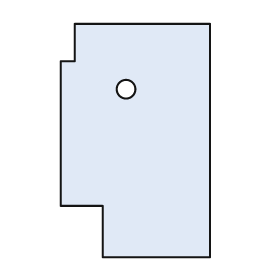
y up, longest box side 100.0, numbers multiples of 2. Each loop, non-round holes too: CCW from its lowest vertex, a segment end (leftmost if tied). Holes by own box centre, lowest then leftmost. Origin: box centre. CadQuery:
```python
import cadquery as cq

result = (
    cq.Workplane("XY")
    .moveTo(-14.0, -50.0)
    .lineTo(32.0, -50.0)
    .lineTo(32.0, 50.0)
    .lineTo(-26.0, 50.0)
    .lineTo(-26.0, 34.0)
    .lineTo(-32.0, 34.0)
    .lineTo(-32.0, -28.0)
    .lineTo(-14.0, -28.0)
    .close()
    .moveTo(-4.0, 22.0)
    .circle(4.0)
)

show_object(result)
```